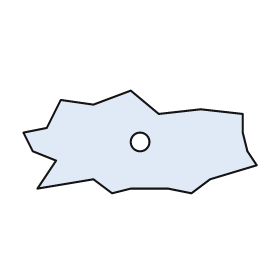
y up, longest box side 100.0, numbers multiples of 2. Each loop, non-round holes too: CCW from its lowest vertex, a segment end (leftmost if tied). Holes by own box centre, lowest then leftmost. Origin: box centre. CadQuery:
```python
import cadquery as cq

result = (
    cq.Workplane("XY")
    .moveTo(-12.0, -22.0)
    .lineTo(-4.0, -20.0)
    .lineTo(12.0, -20.0)
    .lineTo(22.0, -22.0)
    .lineTo(30.0, -16.0)
    .lineTo(50.0, -10.0)
    .lineTo(46.0, -4.0)
    .lineTo(44.0, 4.0)
    .lineTo(44.0, 12.0)
    .lineTo(26.0, 14.0)
    .lineTo(8.0, 12.0)
    .lineTo(-4.0, 22.0)
    .lineTo(-20.0, 16.0)
    .lineTo(-34.0, 18.0)
    .lineTo(-40.0, 6.0)
    .lineTo(-50.0, 4.0)
    .lineTo(-46.0, -4.0)
    .lineTo(-36.0, -8.0)
    .lineTo(-44.0, -20.0)
    .lineTo(-20.0, -16.0)
    .close()
    .moveTo(0.0, 0.0)
    .circle(4.0)
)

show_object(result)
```